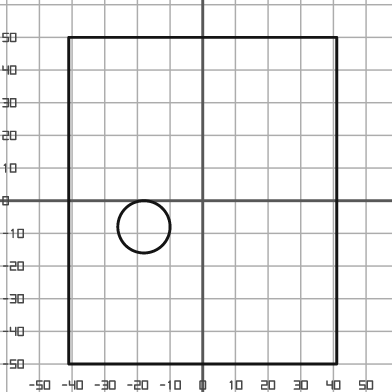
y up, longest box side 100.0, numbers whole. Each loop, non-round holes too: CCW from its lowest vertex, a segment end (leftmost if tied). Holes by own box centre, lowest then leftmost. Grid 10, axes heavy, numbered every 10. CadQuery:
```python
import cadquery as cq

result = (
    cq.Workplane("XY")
    .moveTo(-41.0, -50.0)
    .lineTo(41.0, -50.0)
    .lineTo(41.0, 50.0)
    .lineTo(-41.0, 50.0)
    .close()
    .moveTo(-18.0, -8.0)
    .circle(8.0)
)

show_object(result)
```